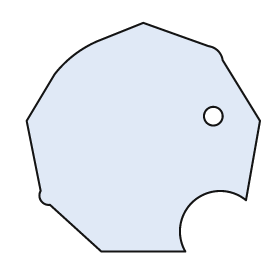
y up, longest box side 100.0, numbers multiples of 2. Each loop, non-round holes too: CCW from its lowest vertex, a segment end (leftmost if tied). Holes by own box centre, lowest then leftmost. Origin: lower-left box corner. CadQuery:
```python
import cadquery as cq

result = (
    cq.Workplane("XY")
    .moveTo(32.0, 0.0)
    .lineTo(68.0, 0.0)
    .threePointArc((72.0, 22.0), (94.0, 22.0))
    .lineTo(100.0, 56.0)
    .lineTo(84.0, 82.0)
    .threePointArc((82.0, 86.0), (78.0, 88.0))
    .lineTo(50.0, 98.0)
    .lineTo(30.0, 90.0)
    .threePointArc((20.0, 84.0), (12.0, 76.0))
    .lineTo(0.0, 56.0)
    .lineTo(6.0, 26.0)
    .threePointArc((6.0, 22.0), (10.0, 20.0))
    .close()
    .moveTo(80.0, 58.0)
    .circle(4.0)
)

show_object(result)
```